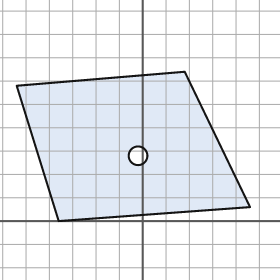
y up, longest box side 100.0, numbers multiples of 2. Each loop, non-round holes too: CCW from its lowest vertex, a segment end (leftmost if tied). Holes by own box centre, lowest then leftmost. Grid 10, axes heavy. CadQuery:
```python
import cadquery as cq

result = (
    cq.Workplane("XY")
    .moveTo(-36.0, 0.0)
    .lineTo(46.0, 6.0)
    .lineTo(18.0, 64.0)
    .lineTo(-54.0, 58.0)
    .close()
    .moveTo(-2.0, 28.0)
    .circle(4.0)
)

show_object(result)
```